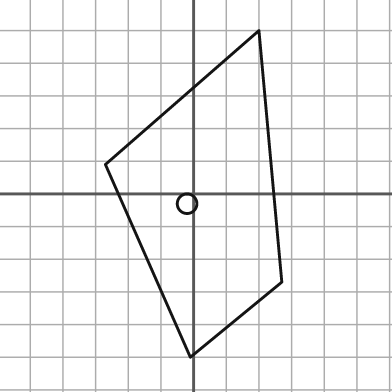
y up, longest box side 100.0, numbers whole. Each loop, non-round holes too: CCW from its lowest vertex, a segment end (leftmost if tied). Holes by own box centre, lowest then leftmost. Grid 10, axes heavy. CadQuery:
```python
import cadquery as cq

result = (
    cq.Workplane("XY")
    .moveTo(-1.0, -50.0)
    .lineTo(27.0, -27.0)
    .lineTo(20.0, 50.0)
    .lineTo(-27.0, 9.0)
    .close()
    .moveTo(-2.0, -3.0)
    .circle(3.0)
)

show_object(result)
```